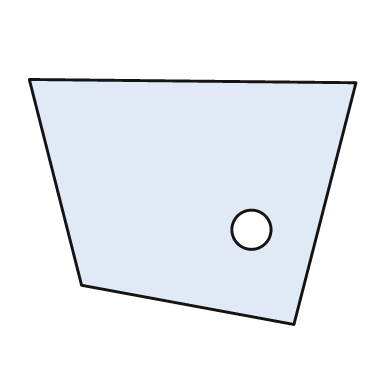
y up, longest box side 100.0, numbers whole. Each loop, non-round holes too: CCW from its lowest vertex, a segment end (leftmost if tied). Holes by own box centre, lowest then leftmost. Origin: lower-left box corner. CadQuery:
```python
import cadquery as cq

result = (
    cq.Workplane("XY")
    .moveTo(81.0, 0.0)
    .lineTo(100.0, 74.0)
    .lineTo(0.0, 75.0)
    .lineTo(16.0, 12.0)
    .close()
    .moveTo(68.0, 29.0)
    .circle(6.0)
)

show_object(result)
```